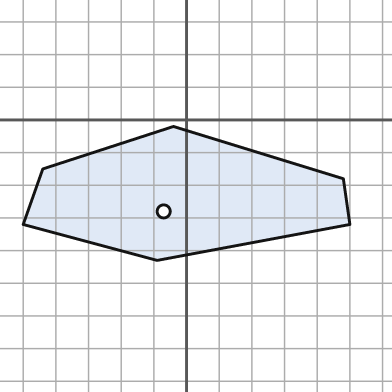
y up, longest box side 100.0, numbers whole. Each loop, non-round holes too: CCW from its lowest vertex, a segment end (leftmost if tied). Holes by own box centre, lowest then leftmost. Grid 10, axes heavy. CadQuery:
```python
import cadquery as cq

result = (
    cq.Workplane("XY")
    .moveTo(-9.0, -43.0)
    .lineTo(50.0, -32.0)
    .lineTo(48.0, -18.0)
    .lineTo(-4.0, -2.0)
    .lineTo(-44.0, -15.0)
    .lineTo(-50.0, -32.0)
    .close()
    .moveTo(-7.0, -28.0)
    .circle(2.0)
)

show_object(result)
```